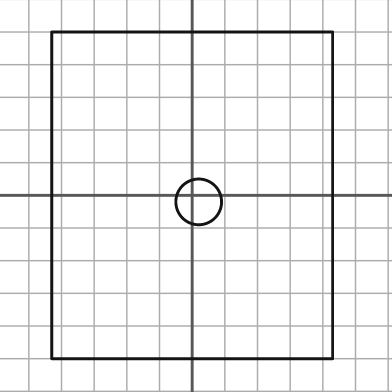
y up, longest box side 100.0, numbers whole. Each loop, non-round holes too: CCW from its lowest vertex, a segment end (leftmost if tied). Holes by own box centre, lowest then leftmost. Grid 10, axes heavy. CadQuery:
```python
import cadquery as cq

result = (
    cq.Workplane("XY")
    .moveTo(-43.0, -50.0)
    .lineTo(43.0, -50.0)
    .lineTo(43.0, 50.0)
    .lineTo(-43.0, 50.0)
    .close()
    .moveTo(2.0, -2.0)
    .circle(7.0)
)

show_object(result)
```